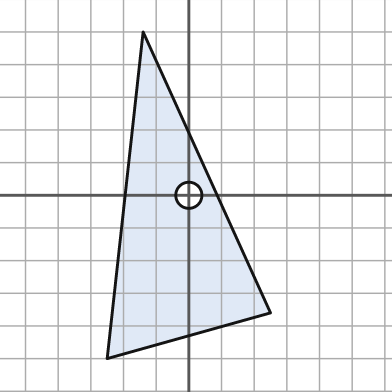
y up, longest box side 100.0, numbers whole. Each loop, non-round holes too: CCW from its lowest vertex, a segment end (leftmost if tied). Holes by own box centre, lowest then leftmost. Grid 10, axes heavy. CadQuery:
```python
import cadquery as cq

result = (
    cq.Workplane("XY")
    .moveTo(-25.0, -50.0)
    .lineTo(25.0, -36.0)
    .lineTo(-14.0, 50.0)
    .close()
    .moveTo(0.0, 0.0)
    .circle(4.0)
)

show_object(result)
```